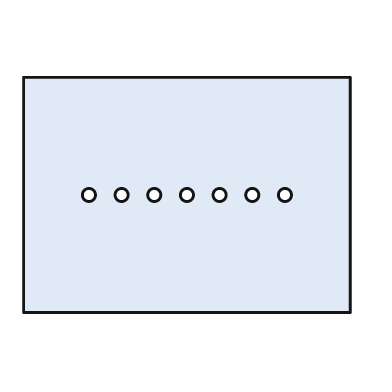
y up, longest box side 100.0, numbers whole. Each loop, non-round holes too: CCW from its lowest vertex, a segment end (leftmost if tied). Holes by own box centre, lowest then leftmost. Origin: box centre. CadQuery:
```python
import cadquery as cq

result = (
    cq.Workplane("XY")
    .moveTo(-50.0, -36.0)
    .lineTo(50.0, -36.0)
    .lineTo(50.0, 36.0)
    .lineTo(-50.0, 36.0)
    .close()
    .moveTo(-30.0, 0.0)
    .circle(2.0)
    .moveTo(-20.0, 0.0)
    .circle(2.0)
    .moveTo(-10.0, 0.0)
    .circle(2.0)
    .moveTo(0.0, 0.0)
    .circle(2.0)
    .moveTo(10.0, 0.0)
    .circle(2.0)
    .moveTo(20.0, 0.0)
    .circle(2.0)
    .moveTo(30.0, 0.0)
    .circle(2.0)
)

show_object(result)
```